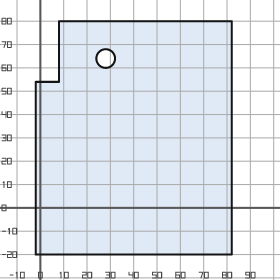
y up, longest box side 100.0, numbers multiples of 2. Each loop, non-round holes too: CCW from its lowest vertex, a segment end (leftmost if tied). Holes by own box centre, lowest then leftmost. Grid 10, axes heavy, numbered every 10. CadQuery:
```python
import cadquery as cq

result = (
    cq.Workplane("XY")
    .moveTo(-2.0, -20.0)
    .lineTo(82.0, -20.0)
    .lineTo(82.0, 80.0)
    .lineTo(8.0, 80.0)
    .lineTo(8.0, 54.0)
    .lineTo(-2.0, 54.0)
    .close()
    .moveTo(28.0, 64.0)
    .circle(4.0)
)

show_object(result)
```